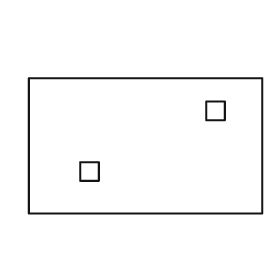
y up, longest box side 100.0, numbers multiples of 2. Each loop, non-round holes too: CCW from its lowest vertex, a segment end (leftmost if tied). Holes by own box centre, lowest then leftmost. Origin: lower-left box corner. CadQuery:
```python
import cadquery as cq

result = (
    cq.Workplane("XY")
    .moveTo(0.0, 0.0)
    .lineTo(100.0, 0.0)
    .lineTo(100.0, 58.0)
    .lineTo(0.0, 58.0)
    .close()
    .moveTo(22.0, 14.0)
    .lineTo(30.0, 14.0)
    .lineTo(30.0, 22.0)
    .lineTo(22.0, 22.0)
    .close()
    .moveTo(76.0, 40.0)
    .lineTo(84.0, 40.0)
    .lineTo(84.0, 48.0)
    .lineTo(76.0, 48.0)
    .close()
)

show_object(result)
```